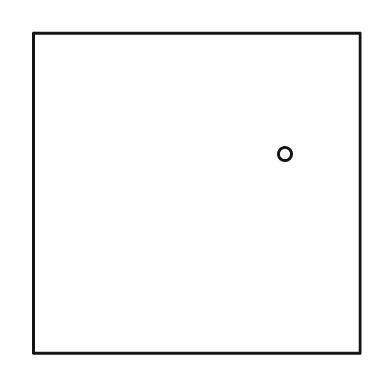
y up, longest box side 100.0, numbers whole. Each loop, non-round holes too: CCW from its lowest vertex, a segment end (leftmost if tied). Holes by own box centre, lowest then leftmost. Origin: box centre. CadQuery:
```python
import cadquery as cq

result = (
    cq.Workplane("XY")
    .moveTo(-50.0, -49.0)
    .lineTo(50.0, -49.0)
    .lineTo(50.0, 49.0)
    .lineTo(-50.0, 49.0)
    .close()
    .moveTo(27.0, 12.0)
    .circle(2.0)
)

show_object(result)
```